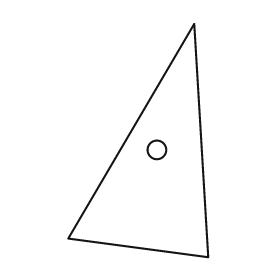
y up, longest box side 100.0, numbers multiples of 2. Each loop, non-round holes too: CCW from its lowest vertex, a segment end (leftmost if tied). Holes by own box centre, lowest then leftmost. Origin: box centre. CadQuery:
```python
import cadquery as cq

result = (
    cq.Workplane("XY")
    .moveTo(30.0, -50.0)
    .lineTo(24.0, 50.0)
    .lineTo(-30.0, -42.0)
    .close()
    .moveTo(8.0, -4.0)
    .circle(4.0)
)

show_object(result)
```